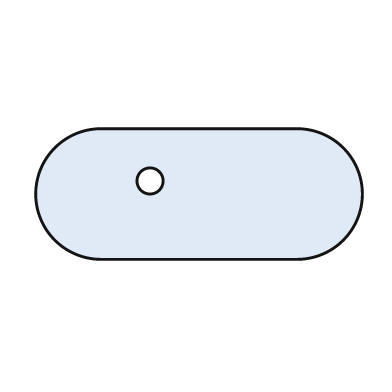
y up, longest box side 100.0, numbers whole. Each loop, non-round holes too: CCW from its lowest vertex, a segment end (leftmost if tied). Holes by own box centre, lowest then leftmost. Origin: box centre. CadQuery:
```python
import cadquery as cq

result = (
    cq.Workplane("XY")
    .moveTo(-30.0, -20.0)
    .lineTo(30.0, -20.0)
    .threePointArc((50.0, 0.0), (30.0, 20.0))
    .lineTo(-30.0, 20.0)
    .threePointArc((-50.0, 0.0), (-30.0, -20.0))
    .close()
    .moveTo(-15.0, 4.0)
    .circle(4.0)
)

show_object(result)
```